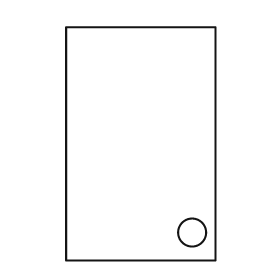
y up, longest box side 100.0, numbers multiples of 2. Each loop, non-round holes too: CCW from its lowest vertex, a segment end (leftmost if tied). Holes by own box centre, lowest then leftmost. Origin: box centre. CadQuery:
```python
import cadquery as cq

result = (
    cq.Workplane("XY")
    .moveTo(-32.0, -50.0)
    .lineTo(32.0, -50.0)
    .lineTo(32.0, 50.0)
    .lineTo(-32.0, 50.0)
    .close()
    .moveTo(22.0, -38.0)
    .circle(6.0)
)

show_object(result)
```